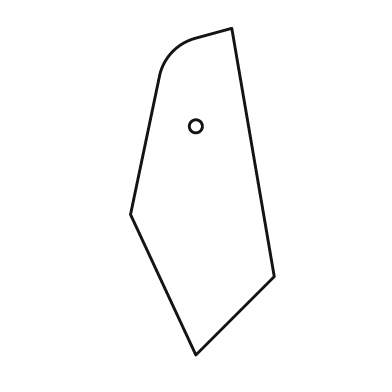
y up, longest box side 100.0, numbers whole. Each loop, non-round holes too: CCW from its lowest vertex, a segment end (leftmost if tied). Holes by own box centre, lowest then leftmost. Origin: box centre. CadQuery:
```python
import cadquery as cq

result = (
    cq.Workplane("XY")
    .moveTo(-2.0, -50.0)
    .lineTo(22.0, -26.0)
    .lineTo(9.0, 50.0)
    .lineTo(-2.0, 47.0)
    .threePointArc((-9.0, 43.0), (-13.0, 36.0))
    .lineTo(-22.0, -7.0)
    .close()
    .moveTo(-2.0, 20.0)
    .circle(2.0)
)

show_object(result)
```